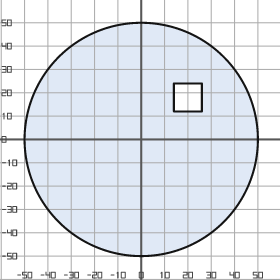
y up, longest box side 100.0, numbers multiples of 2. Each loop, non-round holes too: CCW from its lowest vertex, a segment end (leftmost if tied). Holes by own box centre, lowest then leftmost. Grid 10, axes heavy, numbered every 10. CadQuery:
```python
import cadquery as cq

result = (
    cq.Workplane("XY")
    .moveTo(0.0, 0.0)
    .circle(50.0)
    .moveTo(14.0, 12.0)
    .lineTo(26.0, 12.0)
    .lineTo(26.0, 24.0)
    .lineTo(14.0, 24.0)
    .close()
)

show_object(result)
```